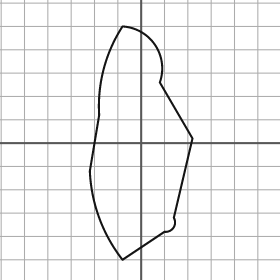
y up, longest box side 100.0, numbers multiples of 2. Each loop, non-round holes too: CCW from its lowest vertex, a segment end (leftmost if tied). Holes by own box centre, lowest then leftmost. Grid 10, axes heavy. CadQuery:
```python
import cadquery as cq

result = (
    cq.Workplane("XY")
    .moveTo(-8.0, -50.0)
    .lineTo(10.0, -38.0)
    .threePointArc((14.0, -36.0), (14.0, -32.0))
    .lineTo(22.0, 2.0)
    .lineTo(8.0, 26.0)
    .threePointArc((6.0, 42.0), (-8.0, 50.0))
    .threePointArc((-16.0, 32.0), (-18.0, 12.0))
    .lineTo(-22.0, -12.0)
    .threePointArc((-18.0, -32.0), (-8.0, -50.0))
    .close()
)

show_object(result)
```